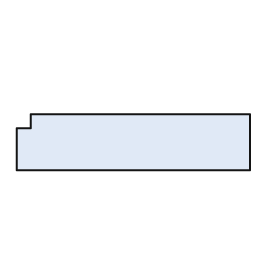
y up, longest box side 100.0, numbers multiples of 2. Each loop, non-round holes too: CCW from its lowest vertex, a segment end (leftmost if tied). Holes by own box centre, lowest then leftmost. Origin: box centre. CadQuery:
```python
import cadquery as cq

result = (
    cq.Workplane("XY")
    .moveTo(-50.0, -12.0)
    .lineTo(50.0, -12.0)
    .lineTo(50.0, 12.0)
    .lineTo(-44.0, 12.0)
    .lineTo(-44.0, 6.0)
    .lineTo(-50.0, 6.0)
    .close()
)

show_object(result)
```